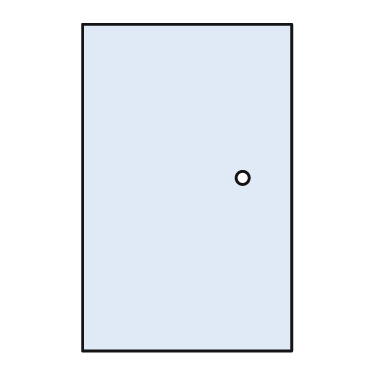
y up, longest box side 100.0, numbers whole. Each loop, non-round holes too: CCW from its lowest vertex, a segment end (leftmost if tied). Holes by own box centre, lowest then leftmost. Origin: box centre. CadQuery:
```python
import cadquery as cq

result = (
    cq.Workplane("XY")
    .moveTo(-32.0, -50.0)
    .lineTo(32.0, -50.0)
    .lineTo(32.0, 50.0)
    .lineTo(-32.0, 50.0)
    .close()
    .moveTo(17.0, 3.0)
    .circle(2.0)
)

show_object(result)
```